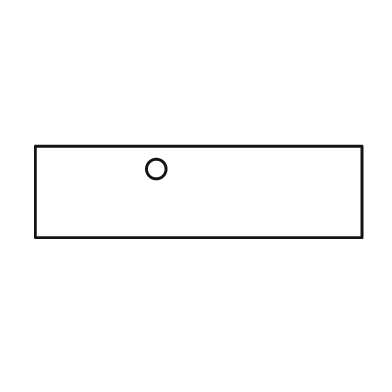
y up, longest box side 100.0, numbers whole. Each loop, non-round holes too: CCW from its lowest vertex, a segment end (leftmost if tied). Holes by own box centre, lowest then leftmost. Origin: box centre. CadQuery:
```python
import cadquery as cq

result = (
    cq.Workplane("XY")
    .moveTo(-50.0, -14.0)
    .lineTo(50.0, -14.0)
    .lineTo(50.0, 14.0)
    .lineTo(-50.0, 14.0)
    .close()
    .moveTo(-13.0, 7.0)
    .circle(3.0)
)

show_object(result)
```